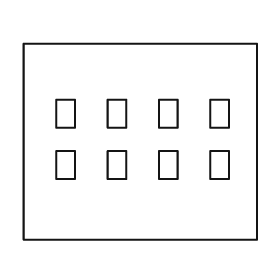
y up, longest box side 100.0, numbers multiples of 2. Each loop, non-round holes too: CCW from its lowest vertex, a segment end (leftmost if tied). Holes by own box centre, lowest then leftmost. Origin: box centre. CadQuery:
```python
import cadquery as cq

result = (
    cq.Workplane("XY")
    .moveTo(-50.0, -42.0)
    .lineTo(50.0, -42.0)
    .lineTo(50.0, 42.0)
    .lineTo(-50.0, 42.0)
    .close()
    .moveTo(-36.0, -16.0)
    .lineTo(-28.0, -16.0)
    .lineTo(-28.0, -4.0)
    .lineTo(-36.0, -4.0)
    .close()
    .moveTo(-14.0, -16.0)
    .lineTo(-6.0, -16.0)
    .lineTo(-6.0, -4.0)
    .lineTo(-14.0, -4.0)
    .close()
    .moveTo(8.0, -16.0)
    .lineTo(16.0, -16.0)
    .lineTo(16.0, -4.0)
    .lineTo(8.0, -4.0)
    .close()
    .moveTo(30.0, -16.0)
    .lineTo(38.0, -16.0)
    .lineTo(38.0, -4.0)
    .lineTo(30.0, -4.0)
    .close()
    .moveTo(-36.0, 6.0)
    .lineTo(-28.0, 6.0)
    .lineTo(-28.0, 18.0)
    .lineTo(-36.0, 18.0)
    .close()
    .moveTo(-14.0, 6.0)
    .lineTo(-6.0, 6.0)
    .lineTo(-6.0, 18.0)
    .lineTo(-14.0, 18.0)
    .close()
    .moveTo(8.0, 6.0)
    .lineTo(16.0, 6.0)
    .lineTo(16.0, 18.0)
    .lineTo(8.0, 18.0)
    .close()
    .moveTo(30.0, 6.0)
    .lineTo(38.0, 6.0)
    .lineTo(38.0, 18.0)
    .lineTo(30.0, 18.0)
    .close()
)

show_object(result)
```